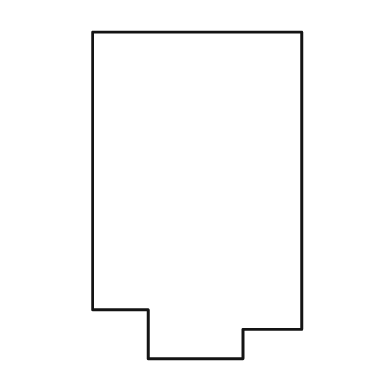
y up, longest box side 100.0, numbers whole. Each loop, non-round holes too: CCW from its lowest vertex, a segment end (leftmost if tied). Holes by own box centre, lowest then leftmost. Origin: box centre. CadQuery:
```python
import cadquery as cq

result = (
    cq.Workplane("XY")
    .moveTo(-15.0, -50.0)
    .lineTo(14.0, -50.0)
    .lineTo(14.0, -41.0)
    .lineTo(32.0, -41.0)
    .lineTo(32.0, 50.0)
    .lineTo(-32.0, 50.0)
    .lineTo(-32.0, -35.0)
    .lineTo(-15.0, -35.0)
    .close()
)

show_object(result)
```